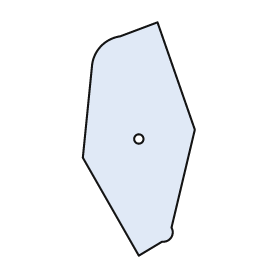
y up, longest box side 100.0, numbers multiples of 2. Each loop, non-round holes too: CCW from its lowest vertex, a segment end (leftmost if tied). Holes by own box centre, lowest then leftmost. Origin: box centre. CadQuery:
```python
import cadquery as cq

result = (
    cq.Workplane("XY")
    .moveTo(0.0, -50.0)
    .lineTo(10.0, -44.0)
    .threePointArc((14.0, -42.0), (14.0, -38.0))
    .lineTo(24.0, 4.0)
    .lineTo(8.0, 50.0)
    .lineTo(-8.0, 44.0)
    .threePointArc((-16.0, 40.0), (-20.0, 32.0))
    .lineTo(-24.0, -8.0)
    .close()
    .moveTo(0.0, 0.0)
    .circle(2.0)
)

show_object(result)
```